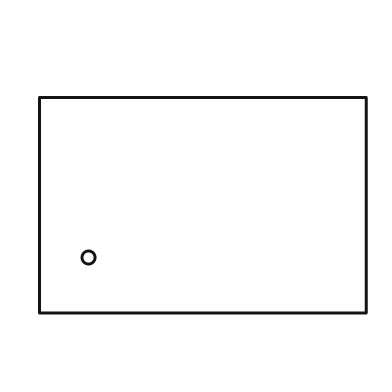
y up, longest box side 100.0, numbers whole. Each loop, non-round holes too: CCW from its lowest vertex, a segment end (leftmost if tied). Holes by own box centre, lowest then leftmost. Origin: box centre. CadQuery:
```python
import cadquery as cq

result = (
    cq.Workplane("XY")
    .moveTo(-50.0, -33.0)
    .lineTo(50.0, -33.0)
    .lineTo(50.0, 33.0)
    .lineTo(-50.0, 33.0)
    .close()
    .moveTo(-35.0, -16.0)
    .circle(2.0)
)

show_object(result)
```